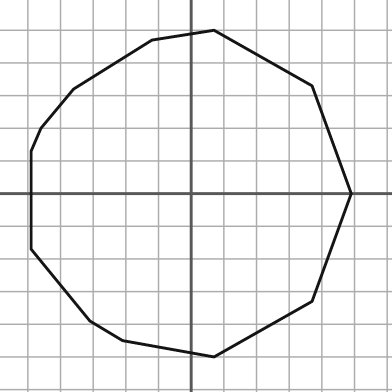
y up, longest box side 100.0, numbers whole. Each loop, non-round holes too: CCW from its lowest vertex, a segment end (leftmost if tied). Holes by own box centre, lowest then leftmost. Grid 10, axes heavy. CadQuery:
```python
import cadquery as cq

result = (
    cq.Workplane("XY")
    .moveTo(7.0, -50.0)
    .lineTo(37.0, -33.0)
    .lineTo(49.0, 0.0)
    .lineTo(37.0, 33.0)
    .lineTo(7.0, 50.0)
    .lineTo(-12.0, 47.0)
    .lineTo(-36.0, 32.0)
    .lineTo(-46.0, 20.0)
    .lineTo(-49.0, 13.0)
    .lineTo(-49.0, -17.0)
    .lineTo(-31.0, -39.0)
    .lineTo(-21.0, -45.0)
    .close()
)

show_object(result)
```